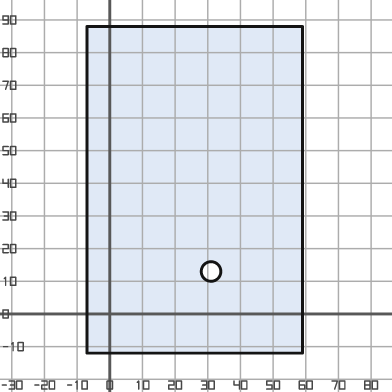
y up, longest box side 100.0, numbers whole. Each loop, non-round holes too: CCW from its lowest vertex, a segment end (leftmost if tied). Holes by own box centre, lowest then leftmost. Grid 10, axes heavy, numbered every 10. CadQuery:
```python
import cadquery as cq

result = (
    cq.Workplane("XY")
    .moveTo(-7.0, -12.0)
    .lineTo(59.0, -12.0)
    .lineTo(59.0, 88.0)
    .lineTo(-7.0, 88.0)
    .close()
    .moveTo(31.0, 13.0)
    .circle(3.0)
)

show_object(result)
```